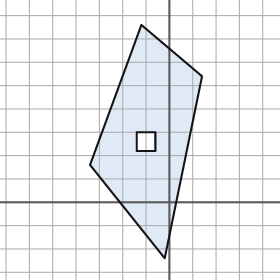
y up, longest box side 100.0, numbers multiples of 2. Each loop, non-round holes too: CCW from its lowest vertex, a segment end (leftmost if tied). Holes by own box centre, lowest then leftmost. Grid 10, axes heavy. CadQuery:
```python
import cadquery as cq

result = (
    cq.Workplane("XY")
    .moveTo(-2.0, -24.0)
    .lineTo(14.0, 54.0)
    .lineTo(-12.0, 76.0)
    .lineTo(-34.0, 16.0)
    .close()
    .moveTo(-14.0, 22.0)
    .lineTo(-6.0, 22.0)
    .lineTo(-6.0, 30.0)
    .lineTo(-14.0, 30.0)
    .close()
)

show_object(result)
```